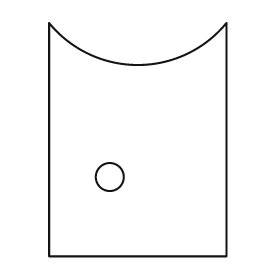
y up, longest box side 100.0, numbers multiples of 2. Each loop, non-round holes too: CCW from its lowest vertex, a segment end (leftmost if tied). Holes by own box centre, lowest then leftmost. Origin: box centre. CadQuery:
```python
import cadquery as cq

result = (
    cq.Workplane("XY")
    .moveTo(-38.0, -50.0)
    .lineTo(38.0, -50.0)
    .lineTo(38.0, 50.0)
    .threePointArc((0.0, 32.0), (-38.0, 50.0))
    .close()
    .moveTo(-12.0, -16.0)
    .circle(6.0)
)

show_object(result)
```